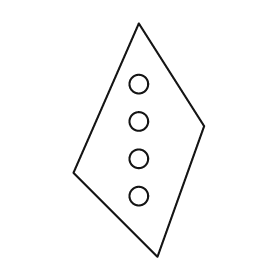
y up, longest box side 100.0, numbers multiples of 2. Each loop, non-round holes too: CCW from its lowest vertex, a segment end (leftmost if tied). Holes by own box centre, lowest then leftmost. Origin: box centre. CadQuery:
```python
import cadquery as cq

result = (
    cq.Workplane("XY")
    .moveTo(8.0, -50.0)
    .lineTo(28.0, 6.0)
    .lineTo(0.0, 50.0)
    .lineTo(-28.0, -14.0)
    .close()
    .moveTo(0.0, -24.0)
    .circle(4.0)
    .moveTo(0.0, -8.0)
    .circle(4.0)
    .moveTo(0.0, 8.0)
    .circle(4.0)
    .moveTo(0.0, 24.0)
    .circle(4.0)
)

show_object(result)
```